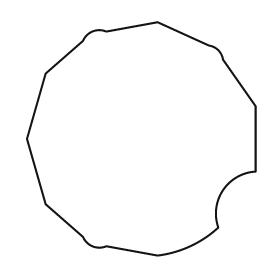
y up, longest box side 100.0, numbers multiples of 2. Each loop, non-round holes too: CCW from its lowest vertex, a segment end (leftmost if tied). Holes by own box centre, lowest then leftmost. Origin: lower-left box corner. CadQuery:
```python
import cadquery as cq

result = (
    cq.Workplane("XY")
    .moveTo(56.0, 0.0)
    .threePointArc((70.0, 4.0), (82.0, 12.0))
    .threePointArc((84.0, 28.0), (98.0, 36.0))
    .lineTo(98.0, 64.0)
    .lineTo(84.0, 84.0)
    .threePointArc((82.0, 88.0), (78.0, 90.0))
    .lineTo(56.0, 100.0)
    .lineTo(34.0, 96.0)
    .threePointArc((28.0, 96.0), (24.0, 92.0))
    .lineTo(8.0, 78.0)
    .lineTo(0.0, 50.0)
    .lineTo(8.0, 22.0)
    .lineTo(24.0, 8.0)
    .threePointArc((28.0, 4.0), (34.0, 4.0))
    .close()
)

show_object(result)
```